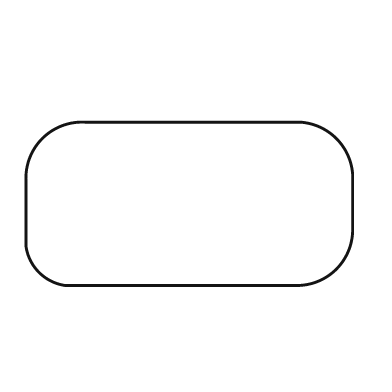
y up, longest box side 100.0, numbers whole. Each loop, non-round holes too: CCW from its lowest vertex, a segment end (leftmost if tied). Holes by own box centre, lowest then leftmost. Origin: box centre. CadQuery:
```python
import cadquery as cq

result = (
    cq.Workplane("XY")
    .moveTo(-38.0, -25.0)
    .lineTo(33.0, -25.0)
    .threePointArc((45.0, -20.0), (50.0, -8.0))
    .lineTo(50.0, 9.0)
    .threePointArc((45.0, 20.0), (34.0, 25.0))
    .lineTo(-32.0, 25.0)
    .threePointArc((-45.0, 20.0), (-50.0, 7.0))
    .lineTo(-50.0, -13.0)
    .threePointArc((-46.0, -21.0), (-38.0, -25.0))
    .close()
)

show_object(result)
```